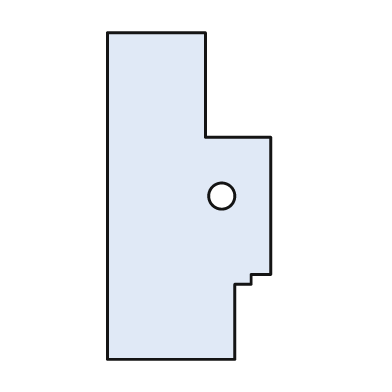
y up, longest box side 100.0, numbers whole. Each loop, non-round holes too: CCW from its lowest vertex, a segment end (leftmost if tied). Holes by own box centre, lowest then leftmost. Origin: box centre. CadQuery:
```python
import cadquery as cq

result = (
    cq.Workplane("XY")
    .moveTo(-25.0, -50.0)
    .lineTo(14.0, -50.0)
    .lineTo(14.0, -27.0)
    .lineTo(19.0, -27.0)
    .lineTo(19.0, -24.0)
    .lineTo(25.0, -24.0)
    .lineTo(25.0, 18.0)
    .lineTo(5.0, 18.0)
    .lineTo(5.0, 50.0)
    .lineTo(-25.0, 50.0)
    .close()
    .moveTo(10.0, 0.0)
    .circle(4.0)
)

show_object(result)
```